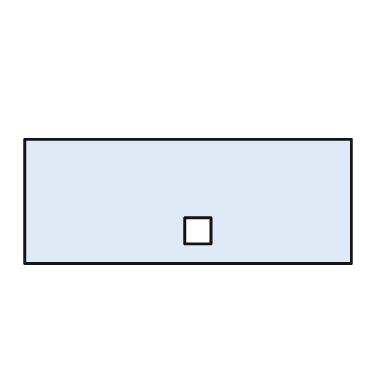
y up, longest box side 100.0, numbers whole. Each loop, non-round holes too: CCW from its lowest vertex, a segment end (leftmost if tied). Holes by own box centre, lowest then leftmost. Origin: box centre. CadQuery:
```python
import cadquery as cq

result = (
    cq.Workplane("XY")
    .moveTo(-50.0, -19.0)
    .lineTo(50.0, -19.0)
    .lineTo(50.0, 19.0)
    .lineTo(-50.0, 19.0)
    .close()
    .moveTo(-1.0, -13.0)
    .lineTo(7.0, -13.0)
    .lineTo(7.0, -5.0)
    .lineTo(-1.0, -5.0)
    .close()
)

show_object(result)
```